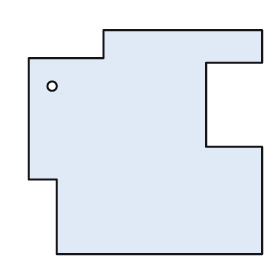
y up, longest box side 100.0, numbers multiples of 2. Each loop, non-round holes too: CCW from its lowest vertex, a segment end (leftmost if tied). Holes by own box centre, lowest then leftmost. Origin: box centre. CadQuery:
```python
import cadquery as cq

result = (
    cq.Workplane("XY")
    .moveTo(-38.0, -48.0)
    .lineTo(50.0, -48.0)
    .lineTo(50.0, -2.0)
    .lineTo(26.0, -2.0)
    .lineTo(26.0, 34.0)
    .lineTo(50.0, 34.0)
    .lineTo(50.0, 48.0)
    .lineTo(-18.0, 48.0)
    .lineTo(-18.0, 36.0)
    .lineTo(-50.0, 36.0)
    .lineTo(-50.0, -16.0)
    .lineTo(-38.0, -16.0)
    .close()
    .moveTo(-40.0, 24.0)
    .circle(2.0)
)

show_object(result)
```